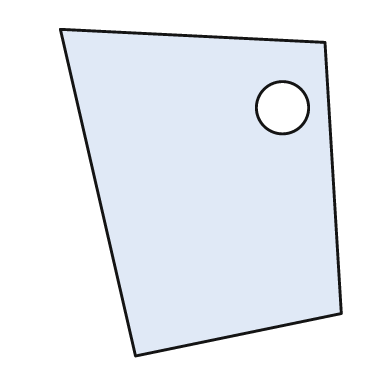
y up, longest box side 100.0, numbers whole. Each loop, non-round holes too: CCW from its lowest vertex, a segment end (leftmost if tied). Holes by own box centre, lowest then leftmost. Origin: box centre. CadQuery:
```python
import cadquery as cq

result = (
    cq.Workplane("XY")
    .moveTo(-20.0, -50.0)
    .lineTo(43.0, -37.0)
    .lineTo(38.0, 46.0)
    .lineTo(-43.0, 50.0)
    .close()
    .moveTo(25.0, 26.0)
    .circle(8.0)
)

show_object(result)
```